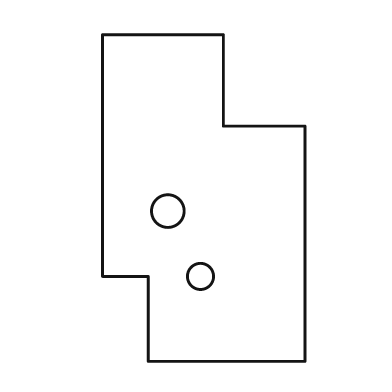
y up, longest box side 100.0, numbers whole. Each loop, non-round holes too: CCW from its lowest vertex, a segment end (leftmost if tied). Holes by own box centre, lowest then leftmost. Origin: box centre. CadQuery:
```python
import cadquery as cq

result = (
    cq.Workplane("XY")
    .moveTo(-17.0, -50.0)
    .lineTo(31.0, -50.0)
    .lineTo(31.0, 22.0)
    .lineTo(6.0, 22.0)
    .lineTo(6.0, 50.0)
    .lineTo(-31.0, 50.0)
    .lineTo(-31.0, -24.0)
    .lineTo(-17.0, -24.0)
    .close()
    .moveTo(-1.0, -24.0)
    .circle(4.0)
    .moveTo(-11.0, -4.0)
    .circle(5.0)
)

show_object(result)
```